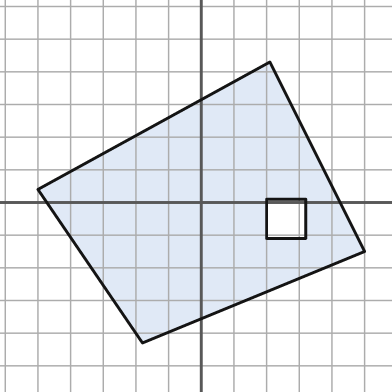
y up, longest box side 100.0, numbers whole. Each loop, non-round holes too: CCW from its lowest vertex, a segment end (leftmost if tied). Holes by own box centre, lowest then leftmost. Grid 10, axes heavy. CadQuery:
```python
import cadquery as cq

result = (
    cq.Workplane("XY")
    .moveTo(-18.0, -43.0)
    .lineTo(50.0, -15.0)
    .lineTo(21.0, 43.0)
    .lineTo(-50.0, 4.0)
    .close()
    .moveTo(20.0, -11.0)
    .lineTo(32.0, -11.0)
    .lineTo(32.0, 1.0)
    .lineTo(20.0, 1.0)
    .close()
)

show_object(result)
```